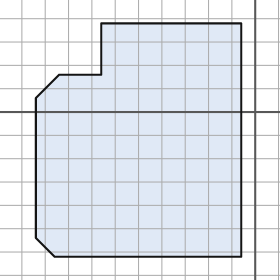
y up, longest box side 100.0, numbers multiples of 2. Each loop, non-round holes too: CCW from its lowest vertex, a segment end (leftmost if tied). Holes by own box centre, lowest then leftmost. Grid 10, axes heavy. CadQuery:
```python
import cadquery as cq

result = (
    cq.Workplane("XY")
    .moveTo(-86.0, -62.0)
    .lineTo(-6.0, -62.0)
    .lineTo(-6.0, 38.0)
    .lineTo(-66.0, 38.0)
    .lineTo(-66.0, 16.0)
    .lineTo(-84.0, 16.0)
    .lineTo(-94.0, 6.0)
    .lineTo(-94.0, -54.0)
    .close()
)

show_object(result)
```